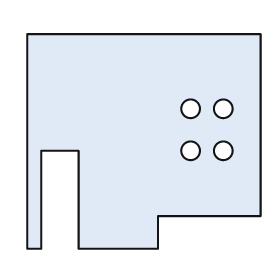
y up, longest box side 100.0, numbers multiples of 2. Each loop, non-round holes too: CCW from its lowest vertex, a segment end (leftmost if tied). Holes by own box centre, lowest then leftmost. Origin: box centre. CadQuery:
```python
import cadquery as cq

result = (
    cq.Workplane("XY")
    .moveTo(-50.0, -46.0)
    .lineTo(-44.0, -46.0)
    .lineTo(-44.0, -4.0)
    .lineTo(-28.0, -4.0)
    .lineTo(-28.0, -46.0)
    .lineTo(6.0, -46.0)
    .lineTo(6.0, -32.0)
    .lineTo(50.0, -32.0)
    .lineTo(50.0, 46.0)
    .lineTo(-50.0, 46.0)
    .close()
    .moveTo(20.0, -4.0)
    .circle(4.0)
    .moveTo(34.0, -4.0)
    .circle(4.0)
    .moveTo(20.0, 14.0)
    .circle(4.0)
    .moveTo(34.0, 14.0)
    .circle(4.0)
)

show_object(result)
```